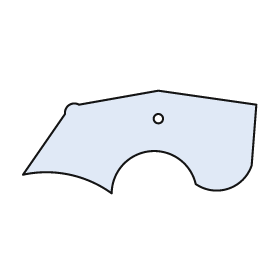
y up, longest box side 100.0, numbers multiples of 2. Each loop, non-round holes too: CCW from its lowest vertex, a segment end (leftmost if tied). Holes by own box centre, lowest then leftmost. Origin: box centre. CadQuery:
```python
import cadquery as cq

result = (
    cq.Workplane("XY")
    .moveTo(-12.0, -22.0)
    .threePointArc((4.0, -4.0), (24.0, -18.0))
    .threePointArc((38.0, -20.0), (48.0, -10.0))
    .lineTo(50.0, 16.0)
    .lineTo(8.0, 22.0)
    .lineTo(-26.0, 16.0)
    .threePointArc((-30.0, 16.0), (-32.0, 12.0))
    .lineTo(-50.0, -14.0)
    .threePointArc((-30.0, -14.0), (-12.0, -22.0))
    .close()
    .moveTo(8.0, 10.0)
    .circle(2.0)
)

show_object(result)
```